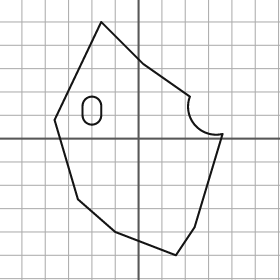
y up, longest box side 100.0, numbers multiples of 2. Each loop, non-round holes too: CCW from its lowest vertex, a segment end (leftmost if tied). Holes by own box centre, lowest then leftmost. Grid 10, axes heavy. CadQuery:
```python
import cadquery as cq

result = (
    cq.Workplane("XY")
    .moveTo(16.0, -50.0)
    .lineTo(24.0, -38.0)
    .lineTo(36.0, 2.0)
    .threePointArc((24.0, 6.0), (22.0, 18.0))
    .lineTo(2.0, 32.0)
    .lineTo(-16.0, 50.0)
    .lineTo(-36.0, 8.0)
    .lineTo(-26.0, -26.0)
    .lineTo(-10.0, -40.0)
    .close()
    .moveTo(-24.0, 10.0)
    .threePointArc((-20.0, 6.0), (-16.0, 10.0))
    .lineTo(-16.0, 14.0)
    .threePointArc((-20.0, 18.0), (-24.0, 14.0))
    .close()
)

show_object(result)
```